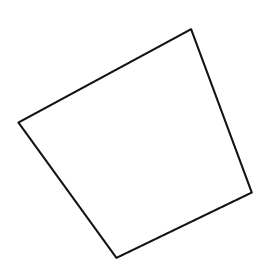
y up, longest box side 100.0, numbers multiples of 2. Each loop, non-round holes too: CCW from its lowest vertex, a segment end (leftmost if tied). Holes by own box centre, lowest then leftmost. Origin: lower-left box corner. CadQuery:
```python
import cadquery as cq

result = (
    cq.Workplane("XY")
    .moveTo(42.0, 0.0)
    .lineTo(100.0, 28.0)
    .lineTo(74.0, 98.0)
    .lineTo(0.0, 58.0)
    .close()
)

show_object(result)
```